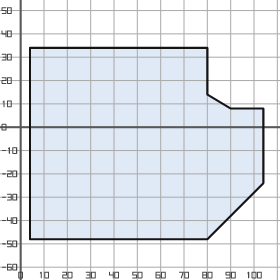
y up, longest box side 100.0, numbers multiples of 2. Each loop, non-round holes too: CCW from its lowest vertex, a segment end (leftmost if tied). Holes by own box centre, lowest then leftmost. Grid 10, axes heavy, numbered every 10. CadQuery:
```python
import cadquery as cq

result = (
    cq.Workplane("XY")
    .moveTo(4.0, -48.0)
    .lineTo(80.0, -48.0)
    .lineTo(104.0, -24.0)
    .lineTo(104.0, 8.0)
    .lineTo(90.0, 8.0)
    .lineTo(80.0, 14.0)
    .lineTo(80.0, 34.0)
    .lineTo(4.0, 34.0)
    .close()
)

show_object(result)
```